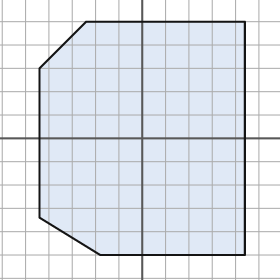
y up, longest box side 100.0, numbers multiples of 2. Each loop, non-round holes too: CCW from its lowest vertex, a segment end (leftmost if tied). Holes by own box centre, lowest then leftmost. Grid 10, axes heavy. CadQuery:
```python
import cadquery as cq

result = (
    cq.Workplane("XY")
    .moveTo(-18.0, -50.0)
    .lineTo(44.0, -50.0)
    .lineTo(44.0, 50.0)
    .lineTo(-24.0, 50.0)
    .lineTo(-44.0, 30.0)
    .lineTo(-44.0, -34.0)
    .close()
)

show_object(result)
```